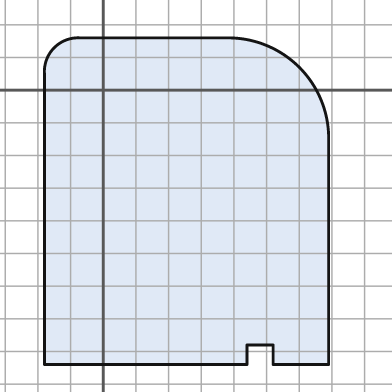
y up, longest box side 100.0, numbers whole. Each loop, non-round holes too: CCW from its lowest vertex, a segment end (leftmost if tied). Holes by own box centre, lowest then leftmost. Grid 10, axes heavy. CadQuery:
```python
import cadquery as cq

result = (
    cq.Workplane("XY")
    .moveTo(-18.0, -84.0)
    .lineTo(44.0, -84.0)
    .lineTo(44.0, -78.0)
    .lineTo(52.0, -78.0)
    .lineTo(52.0, -84.0)
    .lineTo(69.0, -84.0)
    .lineTo(69.0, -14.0)
    .threePointArc((60.0, 7.0), (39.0, 16.0))
    .lineTo(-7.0, 16.0)
    .threePointArc((-15.0, 13.0), (-18.0, 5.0))
    .close()
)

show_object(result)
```